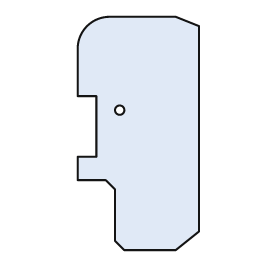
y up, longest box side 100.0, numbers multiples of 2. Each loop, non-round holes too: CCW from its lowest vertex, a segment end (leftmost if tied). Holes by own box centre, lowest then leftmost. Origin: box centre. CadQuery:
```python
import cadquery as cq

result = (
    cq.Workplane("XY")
    .moveTo(-6.0, -50.0)
    .lineTo(16.0, -50.0)
    .lineTo(26.0, -42.0)
    .lineTo(26.0, 46.0)
    .lineTo(16.0, 50.0)
    .lineTo(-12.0, 50.0)
    .threePointArc((-22.0, 46.0), (-26.0, 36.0))
    .lineTo(-26.0, 16.0)
    .lineTo(-18.0, 16.0)
    .lineTo(-18.0, -10.0)
    .lineTo(-26.0, -10.0)
    .lineTo(-26.0, -20.0)
    .lineTo(-14.0, -20.0)
    .lineTo(-10.0, -24.0)
    .lineTo(-10.0, -46.0)
    .close()
    .moveTo(-8.0, 10.0)
    .circle(2.0)
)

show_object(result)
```